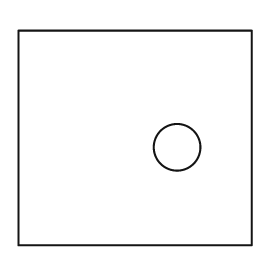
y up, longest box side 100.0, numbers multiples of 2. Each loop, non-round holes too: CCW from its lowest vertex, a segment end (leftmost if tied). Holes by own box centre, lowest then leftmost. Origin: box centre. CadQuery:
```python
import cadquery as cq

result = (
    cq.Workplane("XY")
    .moveTo(-50.0, -46.0)
    .lineTo(50.0, -46.0)
    .lineTo(50.0, 46.0)
    .lineTo(-50.0, 46.0)
    .close()
    .moveTo(18.0, -4.0)
    .circle(10.0)
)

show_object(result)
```